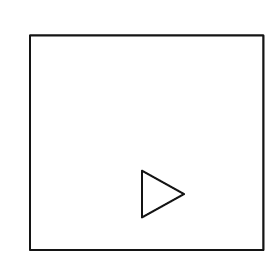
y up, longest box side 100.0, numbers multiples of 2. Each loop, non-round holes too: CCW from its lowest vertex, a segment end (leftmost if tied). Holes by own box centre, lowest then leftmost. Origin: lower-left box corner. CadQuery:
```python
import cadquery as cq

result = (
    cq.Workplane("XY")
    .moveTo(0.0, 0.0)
    .lineTo(100.0, 0.0)
    .lineTo(100.0, 92.0)
    .lineTo(0.0, 92.0)
    .close()
    .moveTo(48.0, 14.0)
    .lineTo(66.0, 24.0)
    .lineTo(48.0, 34.0)
    .close()
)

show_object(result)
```